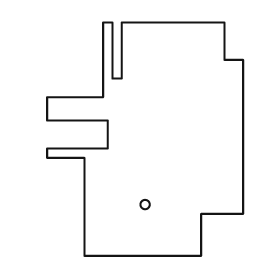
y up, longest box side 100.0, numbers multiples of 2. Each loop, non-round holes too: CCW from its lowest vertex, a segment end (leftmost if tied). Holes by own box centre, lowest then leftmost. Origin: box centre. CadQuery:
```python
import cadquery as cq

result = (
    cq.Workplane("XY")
    .moveTo(-26.0, -50.0)
    .lineTo(24.0, -50.0)
    .lineTo(24.0, -32.0)
    .lineTo(42.0, -32.0)
    .lineTo(42.0, 34.0)
    .lineTo(34.0, 34.0)
    .lineTo(34.0, 50.0)
    .lineTo(-10.0, 50.0)
    .lineTo(-10.0, 26.0)
    .lineTo(-14.0, 26.0)
    .lineTo(-14.0, 50.0)
    .lineTo(-18.0, 50.0)
    .lineTo(-18.0, 18.0)
    .lineTo(-42.0, 18.0)
    .lineTo(-42.0, 8.0)
    .lineTo(-16.0, 8.0)
    .lineTo(-16.0, -4.0)
    .lineTo(-42.0, -4.0)
    .lineTo(-42.0, -8.0)
    .lineTo(-26.0, -8.0)
    .close()
    .moveTo(0.0, -28.0)
    .circle(2.0)
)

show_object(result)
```